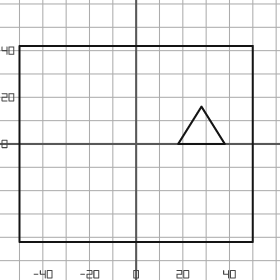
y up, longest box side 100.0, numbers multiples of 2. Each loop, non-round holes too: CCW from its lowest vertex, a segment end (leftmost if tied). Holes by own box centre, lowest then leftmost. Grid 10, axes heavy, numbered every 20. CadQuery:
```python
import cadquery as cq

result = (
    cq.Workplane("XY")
    .moveTo(-50.0, -42.0)
    .lineTo(50.0, -42.0)
    .lineTo(50.0, 42.0)
    .lineTo(-50.0, 42.0)
    .close()
    .moveTo(18.0, 0.0)
    .lineTo(38.0, 0.0)
    .lineTo(28.0, 16.0)
    .close()
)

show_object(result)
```